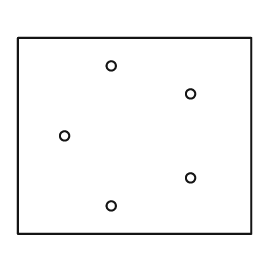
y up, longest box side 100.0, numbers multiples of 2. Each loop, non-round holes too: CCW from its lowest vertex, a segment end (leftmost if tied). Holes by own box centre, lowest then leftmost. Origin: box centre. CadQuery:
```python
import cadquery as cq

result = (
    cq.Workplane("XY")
    .moveTo(-50.0, -42.0)
    .lineTo(50.0, -42.0)
    .lineTo(50.0, 42.0)
    .lineTo(-50.0, 42.0)
    .close()
    .moveTo(-10.0, -30.0)
    .circle(2.0)
    .moveTo(24.0, -18.0)
    .circle(2.0)
    .moveTo(-30.0, 0.0)
    .circle(2.0)
    .moveTo(24.0, 18.0)
    .circle(2.0)
    .moveTo(-10.0, 30.0)
    .circle(2.0)
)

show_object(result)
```